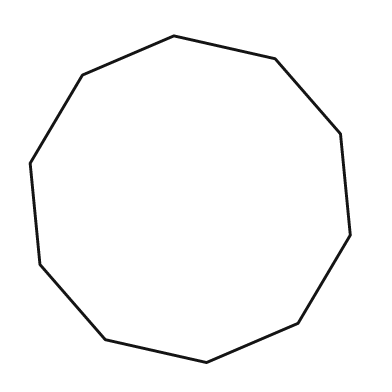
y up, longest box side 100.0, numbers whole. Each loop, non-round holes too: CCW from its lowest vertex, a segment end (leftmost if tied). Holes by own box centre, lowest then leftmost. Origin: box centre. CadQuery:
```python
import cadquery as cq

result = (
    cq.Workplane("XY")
    .moveTo(5.0, -50.0)
    .lineTo(33.0, -38.0)
    .lineTo(49.0, -11.0)
    .lineTo(46.0, 20.0)
    .lineTo(26.0, 43.0)
    .lineTo(-5.0, 50.0)
    .lineTo(-33.0, 38.0)
    .lineTo(-49.0, 11.0)
    .lineTo(-46.0, -20.0)
    .lineTo(-26.0, -43.0)
    .close()
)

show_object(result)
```